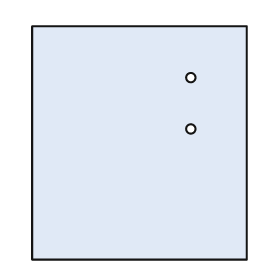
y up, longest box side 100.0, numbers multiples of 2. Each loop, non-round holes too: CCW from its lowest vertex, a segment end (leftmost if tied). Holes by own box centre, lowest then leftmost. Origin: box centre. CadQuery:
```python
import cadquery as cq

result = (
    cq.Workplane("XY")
    .moveTo(-46.0, -50.0)
    .lineTo(46.0, -50.0)
    .lineTo(46.0, 50.0)
    .lineTo(-46.0, 50.0)
    .close()
    .moveTo(22.0, 6.0)
    .circle(2.0)
    .moveTo(22.0, 28.0)
    .circle(2.0)
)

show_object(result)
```